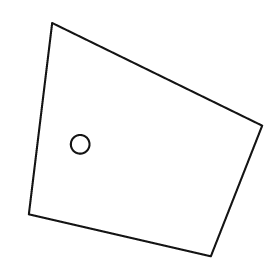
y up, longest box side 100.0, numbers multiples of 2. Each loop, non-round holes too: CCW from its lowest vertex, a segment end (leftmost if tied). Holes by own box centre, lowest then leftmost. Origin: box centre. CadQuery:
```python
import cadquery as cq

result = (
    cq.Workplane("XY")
    .moveTo(28.0, -50.0)
    .lineTo(50.0, 6.0)
    .lineTo(-40.0, 50.0)
    .lineTo(-50.0, -32.0)
    .close()
    .moveTo(-28.0, -2.0)
    .circle(4.0)
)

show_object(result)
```